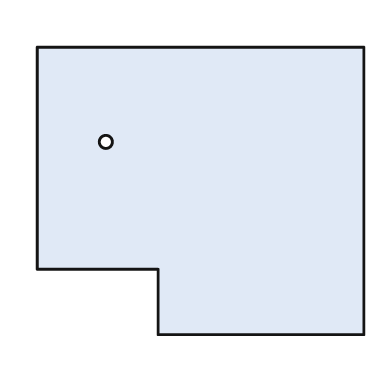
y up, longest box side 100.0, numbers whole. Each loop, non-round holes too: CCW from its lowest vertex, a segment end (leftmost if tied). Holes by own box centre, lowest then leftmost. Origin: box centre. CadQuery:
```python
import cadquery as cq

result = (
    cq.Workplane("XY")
    .moveTo(-13.0, -44.0)
    .lineTo(50.0, -44.0)
    .lineTo(50.0, 44.0)
    .lineTo(-50.0, 44.0)
    .lineTo(-50.0, -24.0)
    .lineTo(-13.0, -24.0)
    .close()
    .moveTo(-29.0, 15.0)
    .circle(2.0)
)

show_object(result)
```